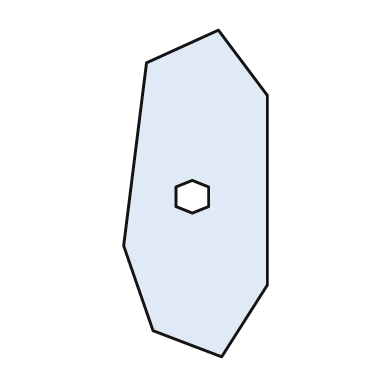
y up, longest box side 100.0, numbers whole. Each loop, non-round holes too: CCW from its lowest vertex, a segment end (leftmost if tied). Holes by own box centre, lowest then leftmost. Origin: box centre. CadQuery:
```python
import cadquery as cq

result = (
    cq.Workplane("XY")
    .moveTo(8.0, -50.0)
    .lineTo(22.0, -28.0)
    .lineTo(22.0, 30.0)
    .lineTo(7.0, 50.0)
    .lineTo(-15.0, 40.0)
    .lineTo(-22.0, -16.0)
    .lineTo(-13.0, -42.0)
    .close()
    .moveTo(-1.0, -6.0)
    .lineTo(4.0, -4.0)
    .lineTo(4.0, 2.0)
    .lineTo(-1.0, 4.0)
    .lineTo(-6.0, 2.0)
    .lineTo(-6.0, -4.0)
    .close()
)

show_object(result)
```